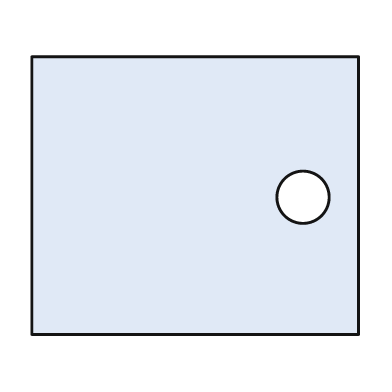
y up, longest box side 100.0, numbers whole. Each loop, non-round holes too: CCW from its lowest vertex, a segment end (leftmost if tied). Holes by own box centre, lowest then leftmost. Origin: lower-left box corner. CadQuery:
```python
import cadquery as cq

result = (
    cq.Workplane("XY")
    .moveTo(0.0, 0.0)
    .lineTo(100.0, 0.0)
    .lineTo(100.0, 85.0)
    .lineTo(0.0, 85.0)
    .close()
    .moveTo(83.0, 42.0)
    .circle(8.0)
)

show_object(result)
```